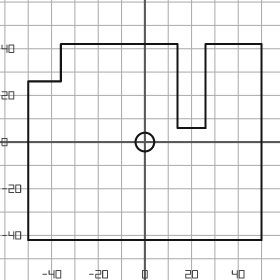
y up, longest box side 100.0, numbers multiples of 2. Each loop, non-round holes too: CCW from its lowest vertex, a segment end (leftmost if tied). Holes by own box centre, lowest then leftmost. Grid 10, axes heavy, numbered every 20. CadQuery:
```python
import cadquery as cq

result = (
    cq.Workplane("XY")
    .moveTo(-50.0, -42.0)
    .lineTo(50.0, -42.0)
    .lineTo(50.0, 42.0)
    .lineTo(26.0, 42.0)
    .lineTo(26.0, 6.0)
    .lineTo(14.0, 6.0)
    .lineTo(14.0, 42.0)
    .lineTo(-36.0, 42.0)
    .lineTo(-36.0, 26.0)
    .lineTo(-50.0, 26.0)
    .close()
    .moveTo(0.0, 0.0)
    .circle(4.0)
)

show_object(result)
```